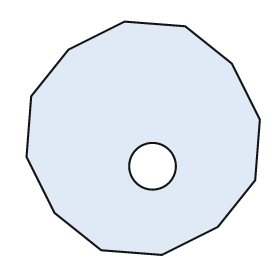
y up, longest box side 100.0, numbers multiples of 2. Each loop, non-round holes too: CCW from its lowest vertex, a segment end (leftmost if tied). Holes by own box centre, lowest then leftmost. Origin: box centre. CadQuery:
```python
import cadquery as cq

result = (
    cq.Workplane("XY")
    .moveTo(8.0, -50.0)
    .lineTo(32.0, -38.0)
    .lineTo(48.0, -18.0)
    .lineTo(50.0, 8.0)
    .lineTo(38.0, 32.0)
    .lineTo(18.0, 48.0)
    .lineTo(-8.0, 50.0)
    .lineTo(-32.0, 38.0)
    .lineTo(-48.0, 18.0)
    .lineTo(-50.0, -8.0)
    .lineTo(-38.0, -32.0)
    .lineTo(-18.0, -48.0)
    .close()
    .moveTo(4.0, -12.0)
    .circle(10.0)
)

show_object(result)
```